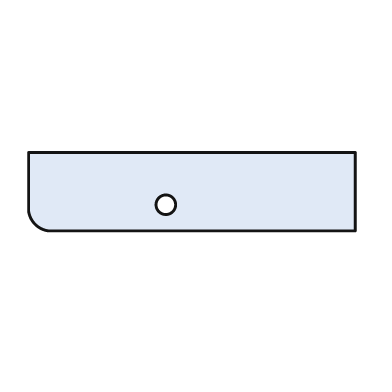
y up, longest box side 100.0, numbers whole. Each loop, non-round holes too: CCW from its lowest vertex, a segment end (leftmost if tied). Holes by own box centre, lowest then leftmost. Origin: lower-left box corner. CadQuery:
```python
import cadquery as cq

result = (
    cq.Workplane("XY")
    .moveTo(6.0, 0.0)
    .lineTo(100.0, 0.0)
    .lineTo(100.0, 24.0)
    .lineTo(0.0, 24.0)
    .lineTo(0.0, 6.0)
    .threePointArc((2.0, 2.0), (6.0, 0.0))
    .close()
    .moveTo(42.0, 8.0)
    .circle(3.0)
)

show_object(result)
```